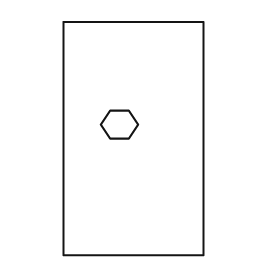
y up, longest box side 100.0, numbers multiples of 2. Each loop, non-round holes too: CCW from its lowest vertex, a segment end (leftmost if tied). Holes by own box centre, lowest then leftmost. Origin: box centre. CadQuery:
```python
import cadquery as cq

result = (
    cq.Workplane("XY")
    .moveTo(-30.0, -50.0)
    .lineTo(30.0, -50.0)
    .lineTo(30.0, 50.0)
    .lineTo(-30.0, 50.0)
    .close()
    .moveTo(-10.0, 0.0)
    .lineTo(-2.0, 0.0)
    .lineTo(2.0, 6.0)
    .lineTo(-2.0, 12.0)
    .lineTo(-10.0, 12.0)
    .lineTo(-14.0, 6.0)
    .close()
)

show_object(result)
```